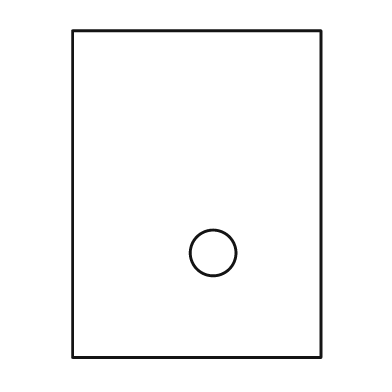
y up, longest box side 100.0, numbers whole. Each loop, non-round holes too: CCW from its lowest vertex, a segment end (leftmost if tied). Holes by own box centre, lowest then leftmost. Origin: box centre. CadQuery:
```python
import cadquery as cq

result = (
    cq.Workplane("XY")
    .moveTo(-38.0, -50.0)
    .lineTo(38.0, -50.0)
    .lineTo(38.0, 50.0)
    .lineTo(-38.0, 50.0)
    .close()
    .moveTo(5.0, -18.0)
    .circle(7.0)
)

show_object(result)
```